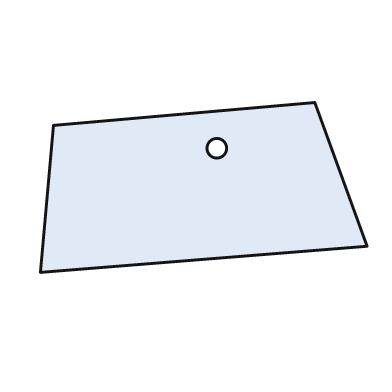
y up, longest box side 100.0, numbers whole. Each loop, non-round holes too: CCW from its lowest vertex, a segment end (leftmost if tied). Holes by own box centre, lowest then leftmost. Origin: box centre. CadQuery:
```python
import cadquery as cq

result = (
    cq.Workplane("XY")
    .moveTo(-50.0, -26.0)
    .lineTo(50.0, -18.0)
    .lineTo(34.0, 26.0)
    .lineTo(-46.0, 19.0)
    .close()
    .moveTo(4.0, 12.0)
    .circle(3.0)
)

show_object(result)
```